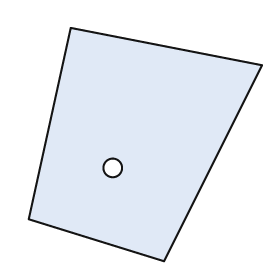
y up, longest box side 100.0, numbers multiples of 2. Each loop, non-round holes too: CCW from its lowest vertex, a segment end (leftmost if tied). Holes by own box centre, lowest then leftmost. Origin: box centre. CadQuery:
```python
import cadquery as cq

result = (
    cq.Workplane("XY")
    .moveTo(8.0, -50.0)
    .lineTo(50.0, 34.0)
    .lineTo(-32.0, 50.0)
    .lineTo(-50.0, -32.0)
    .close()
    .moveTo(-14.0, -10.0)
    .circle(4.0)
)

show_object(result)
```